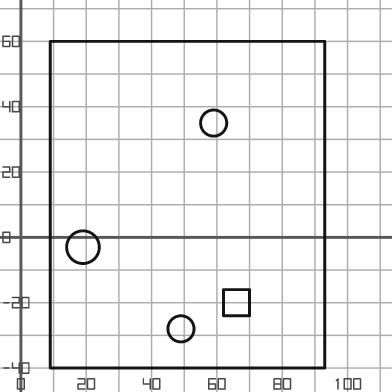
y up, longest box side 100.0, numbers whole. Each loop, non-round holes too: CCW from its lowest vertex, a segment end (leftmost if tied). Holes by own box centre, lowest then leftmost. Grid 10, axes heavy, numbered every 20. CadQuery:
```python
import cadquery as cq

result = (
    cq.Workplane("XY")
    .moveTo(9.0, -40.0)
    .lineTo(93.0, -40.0)
    .lineTo(93.0, 60.0)
    .lineTo(9.0, 60.0)
    .close()
    .moveTo(49.0, -28.0)
    .circle(4.0)
    .moveTo(62.0, -24.0)
    .lineTo(70.0, -24.0)
    .lineTo(70.0, -16.0)
    .lineTo(62.0, -16.0)
    .close()
    .moveTo(19.0, -3.0)
    .circle(5.0)
    .moveTo(59.0, 35.0)
    .circle(4.0)
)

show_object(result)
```